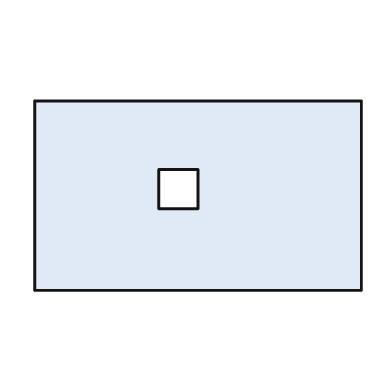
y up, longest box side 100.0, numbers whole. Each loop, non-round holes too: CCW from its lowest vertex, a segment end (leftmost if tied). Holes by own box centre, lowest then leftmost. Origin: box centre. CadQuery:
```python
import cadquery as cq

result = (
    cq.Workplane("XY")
    .moveTo(-50.0, -29.0)
    .lineTo(50.0, -29.0)
    .lineTo(50.0, 29.0)
    .lineTo(-50.0, 29.0)
    .close()
    .moveTo(-12.0, -4.0)
    .lineTo(0.0, -4.0)
    .lineTo(0.0, 8.0)
    .lineTo(-12.0, 8.0)
    .close()
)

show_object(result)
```